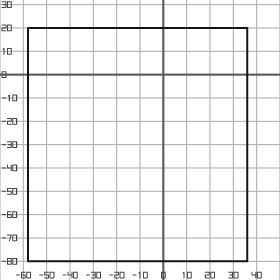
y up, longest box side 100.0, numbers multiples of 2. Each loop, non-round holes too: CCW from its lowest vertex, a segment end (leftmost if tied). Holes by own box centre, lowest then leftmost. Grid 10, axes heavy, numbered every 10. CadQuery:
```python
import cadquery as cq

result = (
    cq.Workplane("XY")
    .moveTo(-58.0, -80.0)
    .lineTo(36.0, -80.0)
    .lineTo(36.0, 20.0)
    .lineTo(-58.0, 20.0)
    .close()
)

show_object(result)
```